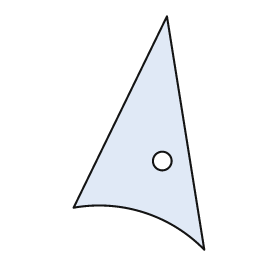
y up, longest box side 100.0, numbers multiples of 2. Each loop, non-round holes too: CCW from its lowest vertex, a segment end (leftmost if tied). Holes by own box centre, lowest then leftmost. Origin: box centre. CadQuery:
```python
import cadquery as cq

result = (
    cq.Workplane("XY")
    .moveTo(28.0, -50.0)
    .lineTo(12.0, 50.0)
    .lineTo(-28.0, -32.0)
    .threePointArc((2.0, -34.0), (28.0, -50.0))
    .close()
    .moveTo(10.0, -12.0)
    .circle(4.0)
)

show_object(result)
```